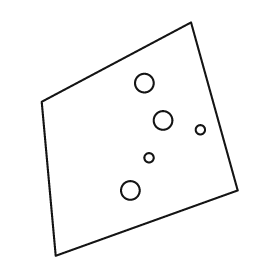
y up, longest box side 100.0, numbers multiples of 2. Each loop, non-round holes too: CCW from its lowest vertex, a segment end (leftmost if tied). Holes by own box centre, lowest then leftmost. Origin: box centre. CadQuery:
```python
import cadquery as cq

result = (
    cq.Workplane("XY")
    .moveTo(-36.0, -50.0)
    .lineTo(42.0, -22.0)
    .lineTo(22.0, 50.0)
    .lineTo(-42.0, 16.0)
    .close()
    .moveTo(-4.0, -22.0)
    .circle(4.0)
    .moveTo(4.0, -8.0)
    .circle(2.0)
    .moveTo(26.0, 4.0)
    .circle(2.0)
    .moveTo(10.0, 8.0)
    .circle(4.0)
    .moveTo(2.0, 24.0)
    .circle(4.0)
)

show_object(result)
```